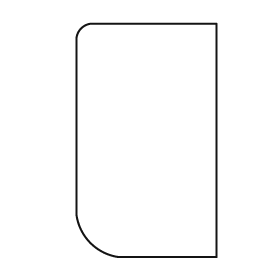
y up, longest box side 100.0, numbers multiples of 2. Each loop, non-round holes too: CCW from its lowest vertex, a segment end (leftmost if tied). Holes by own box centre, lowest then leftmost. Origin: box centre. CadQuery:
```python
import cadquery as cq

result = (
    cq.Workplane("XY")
    .moveTo(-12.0, -50.0)
    .lineTo(30.0, -50.0)
    .lineTo(30.0, 50.0)
    .lineTo(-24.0, 50.0)
    .threePointArc((-28.0, 48.0), (-30.0, 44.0))
    .lineTo(-30.0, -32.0)
    .threePointArc((-24.0, -44.0), (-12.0, -50.0))
    .close()
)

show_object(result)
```